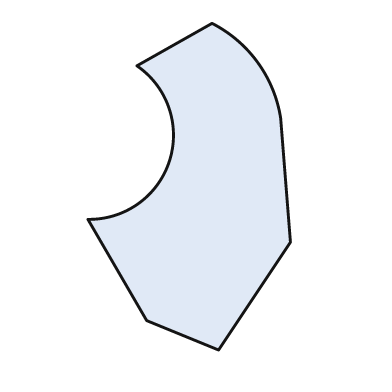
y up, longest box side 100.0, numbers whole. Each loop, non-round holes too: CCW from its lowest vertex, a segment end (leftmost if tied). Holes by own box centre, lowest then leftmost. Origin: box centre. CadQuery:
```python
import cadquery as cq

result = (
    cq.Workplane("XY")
    .moveTo(9.0, -50.0)
    .lineTo(31.0, -17.0)
    .lineTo(28.0, 21.0)
    .threePointArc((21.0, 38.0), (7.0, 50.0))
    .lineTo(-16.0, 37.0)
    .threePointArc((-6.0, 8.0), (-31.0, -10.0))
    .lineTo(-13.0, -41.0)
    .close()
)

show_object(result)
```